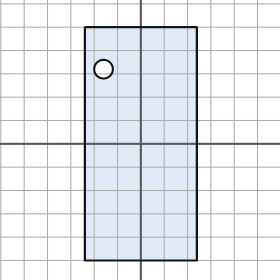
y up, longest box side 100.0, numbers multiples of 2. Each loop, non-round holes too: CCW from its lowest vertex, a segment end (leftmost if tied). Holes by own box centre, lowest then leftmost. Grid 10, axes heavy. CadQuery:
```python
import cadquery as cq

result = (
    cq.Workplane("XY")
    .moveTo(-24.0, -50.0)
    .lineTo(24.0, -50.0)
    .lineTo(24.0, 50.0)
    .lineTo(-24.0, 50.0)
    .close()
    .moveTo(-16.0, 32.0)
    .circle(4.0)
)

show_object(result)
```